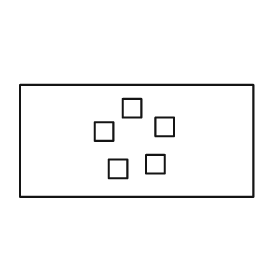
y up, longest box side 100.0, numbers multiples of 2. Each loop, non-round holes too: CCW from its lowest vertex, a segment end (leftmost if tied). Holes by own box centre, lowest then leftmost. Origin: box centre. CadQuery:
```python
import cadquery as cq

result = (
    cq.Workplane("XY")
    .moveTo(-50.0, -24.0)
    .lineTo(50.0, -24.0)
    .lineTo(50.0, 24.0)
    .lineTo(-50.0, 24.0)
    .close()
    .moveTo(-12.0, -16.0)
    .lineTo(-4.0, -16.0)
    .lineTo(-4.0, -8.0)
    .lineTo(-12.0, -8.0)
    .close()
    .moveTo(4.0, -14.0)
    .lineTo(12.0, -14.0)
    .lineTo(12.0, -6.0)
    .lineTo(4.0, -6.0)
    .close()
    .moveTo(-18.0, 0.0)
    .lineTo(-10.0, 0.0)
    .lineTo(-10.0, 8.0)
    .lineTo(-18.0, 8.0)
    .close()
    .moveTo(8.0, 2.0)
    .lineTo(16.0, 2.0)
    .lineTo(16.0, 10.0)
    .lineTo(8.0, 10.0)
    .close()
    .moveTo(-6.0, 10.0)
    .lineTo(2.0, 10.0)
    .lineTo(2.0, 18.0)
    .lineTo(-6.0, 18.0)
    .close()
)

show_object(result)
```